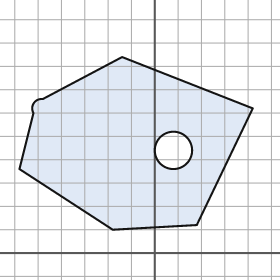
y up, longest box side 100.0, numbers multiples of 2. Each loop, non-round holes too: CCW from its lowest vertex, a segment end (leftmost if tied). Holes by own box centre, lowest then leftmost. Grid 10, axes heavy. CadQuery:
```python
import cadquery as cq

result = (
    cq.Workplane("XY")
    .moveTo(-18.0, 10.0)
    .lineTo(18.0, 12.0)
    .lineTo(42.0, 62.0)
    .lineTo(-14.0, 84.0)
    .lineTo(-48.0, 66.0)
    .threePointArc((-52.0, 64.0), (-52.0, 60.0))
    .lineTo(-58.0, 36.0)
    .close()
    .moveTo(8.0, 44.0)
    .circle(8.0)
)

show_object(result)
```